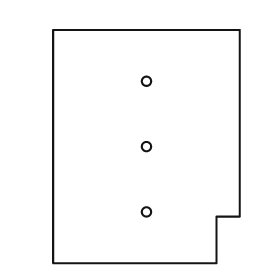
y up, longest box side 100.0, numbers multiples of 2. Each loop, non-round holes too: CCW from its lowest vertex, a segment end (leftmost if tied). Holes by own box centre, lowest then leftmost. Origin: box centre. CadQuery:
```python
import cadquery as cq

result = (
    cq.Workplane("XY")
    .moveTo(-40.0, -50.0)
    .lineTo(30.0, -50.0)
    .lineTo(30.0, -30.0)
    .lineTo(40.0, -30.0)
    .lineTo(40.0, 50.0)
    .lineTo(-40.0, 50.0)
    .close()
    .moveTo(0.0, -28.0)
    .circle(2.0)
    .moveTo(0.0, 0.0)
    .circle(2.0)
    .moveTo(0.0, 28.0)
    .circle(2.0)
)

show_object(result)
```